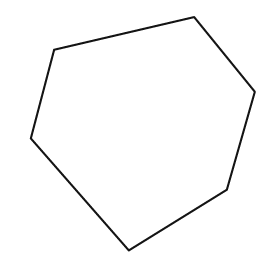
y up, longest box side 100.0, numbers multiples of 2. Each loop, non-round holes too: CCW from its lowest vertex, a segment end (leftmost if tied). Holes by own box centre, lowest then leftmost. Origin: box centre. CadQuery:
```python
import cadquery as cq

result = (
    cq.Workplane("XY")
    .moveTo(-6.0, -50.0)
    .lineTo(36.0, -24.0)
    .lineTo(48.0, 18.0)
    .lineTo(22.0, 50.0)
    .lineTo(-38.0, 36.0)
    .lineTo(-48.0, -2.0)
    .close()
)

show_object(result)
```